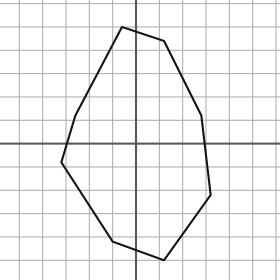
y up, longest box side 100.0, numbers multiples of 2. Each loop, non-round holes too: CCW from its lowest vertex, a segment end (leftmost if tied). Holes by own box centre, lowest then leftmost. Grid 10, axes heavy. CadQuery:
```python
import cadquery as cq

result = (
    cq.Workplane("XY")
    .moveTo(12.0, -50.0)
    .lineTo(32.0, -22.0)
    .lineTo(28.0, 12.0)
    .lineTo(12.0, 44.0)
    .lineTo(-6.0, 50.0)
    .lineTo(-26.0, 12.0)
    .lineTo(-32.0, -8.0)
    .lineTo(-10.0, -42.0)
    .close()
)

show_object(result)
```